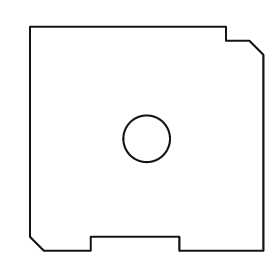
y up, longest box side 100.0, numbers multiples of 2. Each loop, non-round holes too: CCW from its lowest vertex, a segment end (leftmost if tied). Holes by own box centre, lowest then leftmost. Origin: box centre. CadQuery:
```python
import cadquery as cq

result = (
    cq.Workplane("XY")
    .moveTo(-44.0, -48.0)
    .lineTo(-24.0, -48.0)
    .lineTo(-24.0, -42.0)
    .lineTo(14.0, -42.0)
    .lineTo(14.0, -48.0)
    .lineTo(50.0, -48.0)
    .lineTo(50.0, 36.0)
    .lineTo(44.0, 42.0)
    .lineTo(34.0, 42.0)
    .lineTo(34.0, 48.0)
    .lineTo(-50.0, 48.0)
    .lineTo(-50.0, -42.0)
    .close()
    .moveTo(0.0, 0.0)
    .circle(10.0)
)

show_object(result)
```